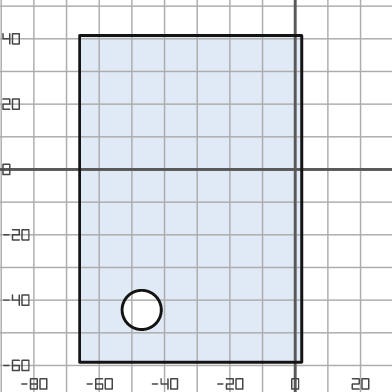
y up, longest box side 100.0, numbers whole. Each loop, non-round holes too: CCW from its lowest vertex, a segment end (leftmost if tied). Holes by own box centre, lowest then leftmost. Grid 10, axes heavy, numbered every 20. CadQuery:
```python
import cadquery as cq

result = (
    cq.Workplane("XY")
    .moveTo(-66.0, -59.0)
    .lineTo(2.0, -59.0)
    .lineTo(2.0, 41.0)
    .lineTo(-66.0, 41.0)
    .close()
    .moveTo(-47.0, -43.0)
    .circle(6.0)
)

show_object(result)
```